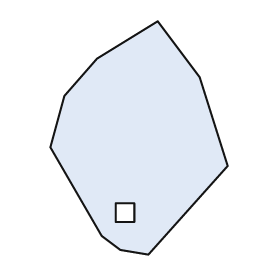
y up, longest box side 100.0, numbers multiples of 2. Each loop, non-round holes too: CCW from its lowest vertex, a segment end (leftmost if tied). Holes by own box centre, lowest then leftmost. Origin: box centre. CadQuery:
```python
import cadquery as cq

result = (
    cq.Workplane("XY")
    .moveTo(4.0, -50.0)
    .lineTo(38.0, -12.0)
    .lineTo(26.0, 26.0)
    .lineTo(8.0, 50.0)
    .lineTo(-18.0, 34.0)
    .lineTo(-32.0, 18.0)
    .lineTo(-38.0, -4.0)
    .lineTo(-16.0, -42.0)
    .lineTo(-8.0, -48.0)
    .close()
    .moveTo(-10.0, -36.0)
    .lineTo(-2.0, -36.0)
    .lineTo(-2.0, -28.0)
    .lineTo(-10.0, -28.0)
    .close()
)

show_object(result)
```